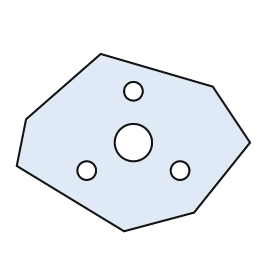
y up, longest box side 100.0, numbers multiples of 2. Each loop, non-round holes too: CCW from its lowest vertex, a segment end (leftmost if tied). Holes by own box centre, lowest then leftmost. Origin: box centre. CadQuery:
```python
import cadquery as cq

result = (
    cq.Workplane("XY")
    .moveTo(-4.0, -38.0)
    .lineTo(26.0, -30.0)
    .lineTo(50.0, 0.0)
    .lineTo(34.0, 24.0)
    .lineTo(-14.0, 38.0)
    .lineTo(-46.0, 10.0)
    .lineTo(-50.0, -10.0)
    .close()
    .moveTo(-20.0, -12.0)
    .circle(4.0)
    .moveTo(20.0, -12.0)
    .circle(4.0)
    .moveTo(0.0, 0.0)
    .circle(8.0)
    .moveTo(0.0, 22.0)
    .circle(4.0)
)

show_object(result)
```